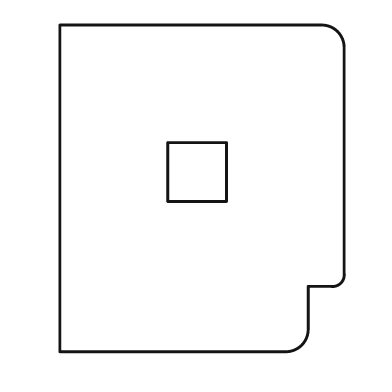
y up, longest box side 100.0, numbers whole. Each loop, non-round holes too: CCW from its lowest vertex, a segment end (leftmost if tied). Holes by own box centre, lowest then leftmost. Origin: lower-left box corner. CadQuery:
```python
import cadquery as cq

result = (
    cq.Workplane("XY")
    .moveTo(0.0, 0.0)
    .lineTo(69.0, 0.0)
    .threePointArc((74.0, 2.0), (76.0, 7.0))
    .lineTo(76.0, 20.0)
    .lineTo(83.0, 20.0)
    .threePointArc((86.0, 21.0), (87.0, 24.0))
    .lineTo(87.0, 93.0)
    .threePointArc((85.0, 98.0), (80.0, 100.0))
    .lineTo(0.0, 100.0)
    .close()
    .moveTo(33.0, 46.0)
    .lineTo(51.0, 46.0)
    .lineTo(51.0, 64.0)
    .lineTo(33.0, 64.0)
    .close()
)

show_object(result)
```